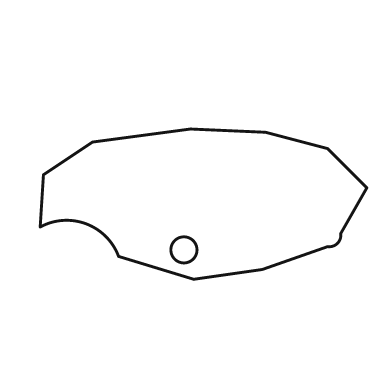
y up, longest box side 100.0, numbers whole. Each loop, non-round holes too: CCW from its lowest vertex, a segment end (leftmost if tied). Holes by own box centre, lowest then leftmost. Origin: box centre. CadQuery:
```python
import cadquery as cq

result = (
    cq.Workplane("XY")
    .moveTo(-3.0, -23.0)
    .lineTo(18.0, -20.0)
    .lineTo(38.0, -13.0)
    .threePointArc((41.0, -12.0), (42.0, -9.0))
    .lineTo(50.0, 5.0)
    .lineTo(38.0, 17.0)
    .lineTo(19.0, 22.0)
    .lineTo(-4.0, 23.0)
    .lineTo(-34.0, 19.0)
    .lineTo(-49.0, 9.0)
    .lineTo(-50.0, -7.0)
    .threePointArc((-36.0, -6.0), (-26.0, -16.0))
    .close()
    .moveTo(-6.0, -14.0)
    .circle(4.0)
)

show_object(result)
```